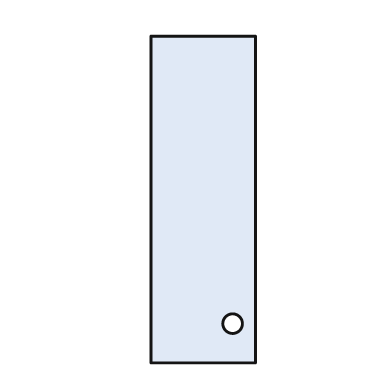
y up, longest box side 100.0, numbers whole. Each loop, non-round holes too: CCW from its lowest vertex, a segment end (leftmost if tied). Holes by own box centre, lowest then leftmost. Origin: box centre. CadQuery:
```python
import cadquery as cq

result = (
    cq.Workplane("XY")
    .moveTo(-16.0, -50.0)
    .lineTo(16.0, -50.0)
    .lineTo(16.0, 50.0)
    .lineTo(-16.0, 50.0)
    .close()
    .moveTo(9.0, -38.0)
    .circle(3.0)
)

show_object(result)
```